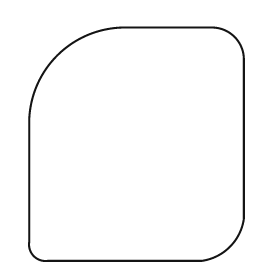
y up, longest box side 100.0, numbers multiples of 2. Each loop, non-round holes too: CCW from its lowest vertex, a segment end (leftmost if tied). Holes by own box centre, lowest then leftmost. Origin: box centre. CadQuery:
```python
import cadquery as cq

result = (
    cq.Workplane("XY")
    .moveTo(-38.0, -50.0)
    .lineTo(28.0, -50.0)
    .threePointArc((40.0, -44.0), (46.0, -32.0))
    .lineTo(46.0, 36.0)
    .threePointArc((42.0, 46.0), (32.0, 50.0))
    .lineTo(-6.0, 50.0)
    .threePointArc((-34.0, 38.0), (-46.0, 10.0))
    .lineTo(-46.0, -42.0)
    .threePointArc((-44.0, -48.0), (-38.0, -50.0))
    .close()
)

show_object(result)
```